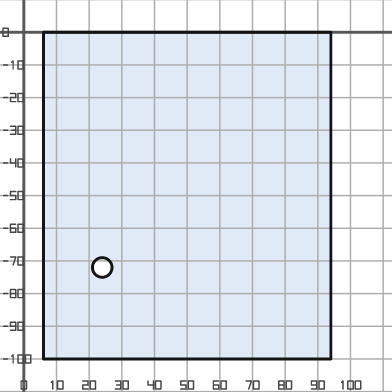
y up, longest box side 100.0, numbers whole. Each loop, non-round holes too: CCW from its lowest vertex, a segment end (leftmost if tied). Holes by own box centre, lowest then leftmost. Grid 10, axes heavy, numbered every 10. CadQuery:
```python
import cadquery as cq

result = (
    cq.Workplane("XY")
    .moveTo(6.0, -100.0)
    .lineTo(94.0, -100.0)
    .lineTo(94.0, 0.0)
    .lineTo(6.0, 0.0)
    .close()
    .moveTo(24.0, -72.0)
    .circle(3.0)
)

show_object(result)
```